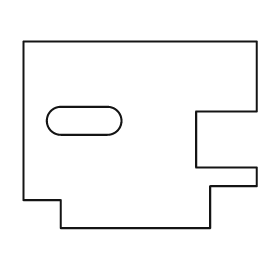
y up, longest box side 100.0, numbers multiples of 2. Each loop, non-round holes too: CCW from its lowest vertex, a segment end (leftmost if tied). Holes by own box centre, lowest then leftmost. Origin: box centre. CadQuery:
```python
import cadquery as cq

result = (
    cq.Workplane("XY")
    .moveTo(-34.0, -40.0)
    .lineTo(30.0, -40.0)
    .lineTo(30.0, -22.0)
    .lineTo(50.0, -22.0)
    .lineTo(50.0, -14.0)
    .lineTo(24.0, -14.0)
    .lineTo(24.0, 10.0)
    .lineTo(50.0, 10.0)
    .lineTo(50.0, 40.0)
    .lineTo(-50.0, 40.0)
    .lineTo(-50.0, -28.0)
    .lineTo(-34.0, -28.0)
    .close()
    .moveTo(-34.0, 0.0)
    .lineTo(-14.0, 0.0)
    .threePointArc((-8.0, 6.0), (-14.0, 12.0))
    .lineTo(-34.0, 12.0)
    .threePointArc((-40.0, 6.0), (-34.0, 0.0))
    .close()
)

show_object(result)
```